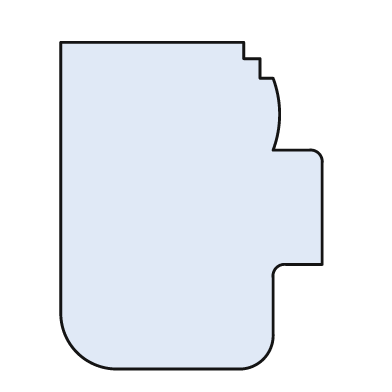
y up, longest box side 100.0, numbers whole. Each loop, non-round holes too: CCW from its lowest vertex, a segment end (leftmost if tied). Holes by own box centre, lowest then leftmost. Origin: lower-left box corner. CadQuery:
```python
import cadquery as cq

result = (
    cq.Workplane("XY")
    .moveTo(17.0, 0.0)
    .lineTo(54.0, 0.0)
    .threePointArc((62.0, 3.0), (65.0, 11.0))
    .lineTo(65.0, 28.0)
    .threePointArc((66.0, 31.0), (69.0, 32.0))
    .lineTo(80.0, 32.0)
    .lineTo(80.0, 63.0)
    .threePointArc((79.0, 66.0), (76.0, 67.0))
    .lineTo(65.0, 67.0)
    .threePointArc((67.0, 78.0), (65.0, 89.0))
    .lineTo(61.0, 89.0)
    .lineTo(61.0, 95.0)
    .lineTo(56.0, 95.0)
    .lineTo(56.0, 100.0)
    .lineTo(0.0, 100.0)
    .lineTo(0.0, 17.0)
    .threePointArc((5.0, 5.0), (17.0, 0.0))
    .close()
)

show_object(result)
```